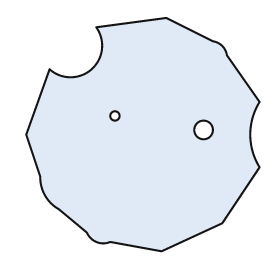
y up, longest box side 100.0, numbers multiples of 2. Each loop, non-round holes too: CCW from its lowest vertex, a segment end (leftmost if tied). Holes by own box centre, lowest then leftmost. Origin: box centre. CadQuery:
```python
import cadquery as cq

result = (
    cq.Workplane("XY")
    .moveTo(8.0, -50.0)
    .lineTo(34.0, -38.0)
    .lineTo(50.0, -14.0)
    .threePointArc((46.0, 0.0), (50.0, 14.0))
    .lineTo(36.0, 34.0)
    .threePointArc((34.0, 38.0), (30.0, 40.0))
    .lineTo(10.0, 50.0)
    .lineTo(-20.0, 46.0)
    .threePointArc((-22.0, 28.0), (-40.0, 28.0))
    .lineTo(-50.0, 0.0)
    .lineTo(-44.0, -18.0)
    .threePointArc((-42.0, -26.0), (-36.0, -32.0))
    .lineTo(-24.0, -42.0)
    .threePointArc((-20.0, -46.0), (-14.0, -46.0))
    .close()
    .moveTo(26.0, 2.0)
    .circle(4.0)
    .moveTo(-12.0, 8.0)
    .circle(2.0)
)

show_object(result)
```